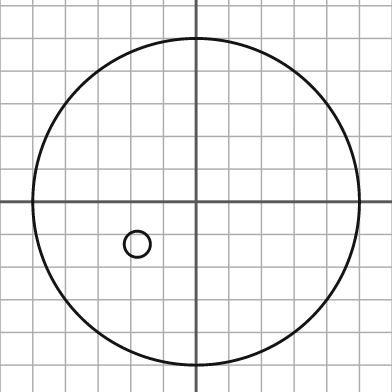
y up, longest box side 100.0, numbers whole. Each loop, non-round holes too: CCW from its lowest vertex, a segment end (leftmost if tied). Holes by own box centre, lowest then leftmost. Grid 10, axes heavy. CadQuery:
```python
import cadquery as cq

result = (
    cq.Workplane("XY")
    .moveTo(0.0, 0.0)
    .circle(50.0)
    .moveTo(-18.0, -13.0)
    .circle(4.0)
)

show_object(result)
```